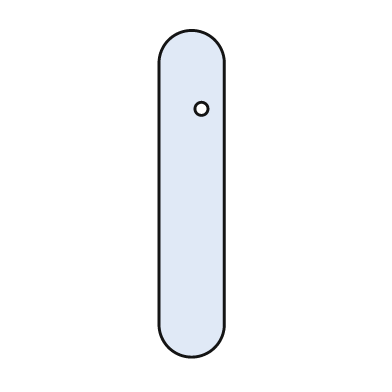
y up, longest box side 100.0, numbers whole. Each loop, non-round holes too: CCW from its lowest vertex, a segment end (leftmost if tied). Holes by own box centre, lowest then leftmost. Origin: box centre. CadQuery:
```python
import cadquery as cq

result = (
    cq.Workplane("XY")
    .moveTo(-10.0, -40.0)
    .threePointArc((0.0, -50.0), (10.0, -40.0))
    .lineTo(10.0, 40.0)
    .threePointArc((0.0, 50.0), (-10.0, 40.0))
    .close()
    .moveTo(3.0, 26.0)
    .circle(2.0)
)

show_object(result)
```